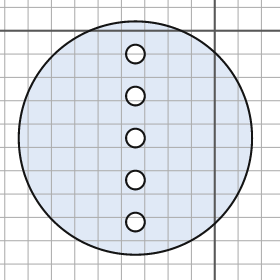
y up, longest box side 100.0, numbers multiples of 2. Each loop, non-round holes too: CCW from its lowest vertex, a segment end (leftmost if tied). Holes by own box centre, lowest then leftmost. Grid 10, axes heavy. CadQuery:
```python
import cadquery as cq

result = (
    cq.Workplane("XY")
    .moveTo(-34.0, -46.0)
    .circle(50.0)
    .moveTo(-34.0, -82.0)
    .circle(4.0)
    .moveTo(-34.0, -64.0)
    .circle(4.0)
    .moveTo(-34.0, -46.0)
    .circle(4.0)
    .moveTo(-34.0, -28.0)
    .circle(4.0)
    .moveTo(-34.0, -10.0)
    .circle(4.0)
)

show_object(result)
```